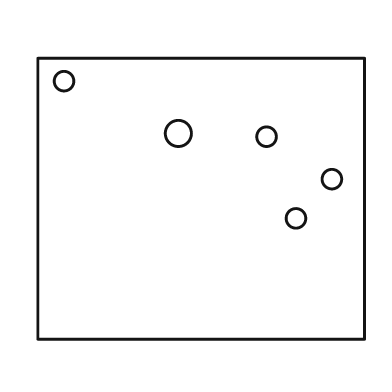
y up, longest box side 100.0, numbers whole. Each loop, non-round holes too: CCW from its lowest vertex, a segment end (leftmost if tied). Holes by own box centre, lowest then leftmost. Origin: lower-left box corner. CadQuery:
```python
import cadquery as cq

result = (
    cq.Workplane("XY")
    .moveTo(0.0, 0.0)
    .lineTo(100.0, 0.0)
    .lineTo(100.0, 86.0)
    .lineTo(0.0, 86.0)
    .close()
    .moveTo(79.0, 37.0)
    .circle(3.0)
    .moveTo(90.0, 49.0)
    .circle(3.0)
    .moveTo(70.0, 62.0)
    .circle(3.0)
    .moveTo(43.0, 63.0)
    .circle(4.0)
    .moveTo(8.0, 79.0)
    .circle(3.0)
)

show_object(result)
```